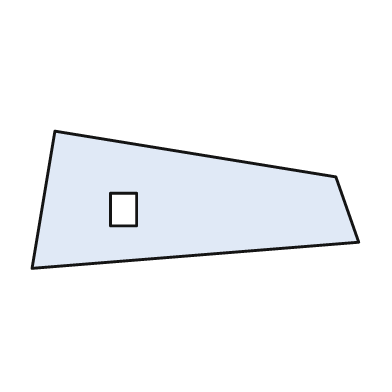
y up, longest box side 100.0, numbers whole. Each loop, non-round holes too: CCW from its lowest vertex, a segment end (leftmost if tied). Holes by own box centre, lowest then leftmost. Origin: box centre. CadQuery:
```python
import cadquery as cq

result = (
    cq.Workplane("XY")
    .moveTo(-50.0, -21.0)
    .lineTo(50.0, -13.0)
    .lineTo(43.0, 7.0)
    .lineTo(-43.0, 21.0)
    .close()
    .moveTo(-26.0, -8.0)
    .lineTo(-18.0, -8.0)
    .lineTo(-18.0, 2.0)
    .lineTo(-26.0, 2.0)
    .close()
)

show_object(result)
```